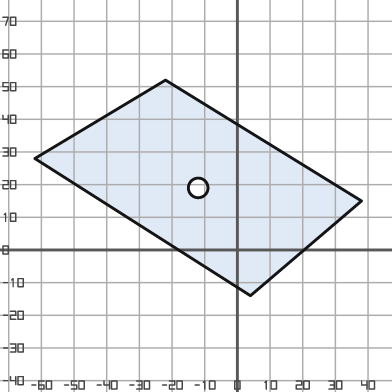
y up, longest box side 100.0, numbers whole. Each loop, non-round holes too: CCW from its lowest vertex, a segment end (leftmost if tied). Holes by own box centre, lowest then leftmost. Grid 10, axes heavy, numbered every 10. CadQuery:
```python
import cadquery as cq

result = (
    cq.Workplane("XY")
    .moveTo(4.0, -14.0)
    .lineTo(38.0, 15.0)
    .lineTo(-22.0, 52.0)
    .lineTo(-62.0, 28.0)
    .close()
    .moveTo(-12.0, 19.0)
    .circle(3.0)
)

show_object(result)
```